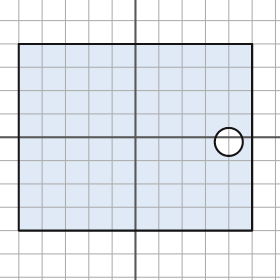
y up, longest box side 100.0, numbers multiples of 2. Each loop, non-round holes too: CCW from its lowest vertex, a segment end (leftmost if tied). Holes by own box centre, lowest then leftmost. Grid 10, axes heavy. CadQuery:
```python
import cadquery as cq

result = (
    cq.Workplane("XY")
    .moveTo(-50.0, -40.0)
    .lineTo(50.0, -40.0)
    .lineTo(50.0, 40.0)
    .lineTo(-50.0, 40.0)
    .close()
    .moveTo(40.0, -2.0)
    .circle(6.0)
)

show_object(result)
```